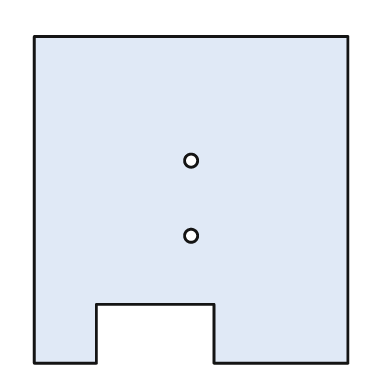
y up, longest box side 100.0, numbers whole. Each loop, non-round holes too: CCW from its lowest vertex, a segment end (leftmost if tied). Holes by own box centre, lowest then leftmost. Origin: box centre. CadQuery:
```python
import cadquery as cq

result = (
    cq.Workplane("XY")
    .moveTo(-48.0, -50.0)
    .lineTo(-29.0, -50.0)
    .lineTo(-29.0, -32.0)
    .lineTo(7.0, -32.0)
    .lineTo(7.0, -50.0)
    .lineTo(48.0, -50.0)
    .lineTo(48.0, 50.0)
    .lineTo(-48.0, 50.0)
    .close()
    .moveTo(0.0, -11.0)
    .circle(2.0)
    .moveTo(0.0, 12.0)
    .circle(2.0)
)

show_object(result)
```